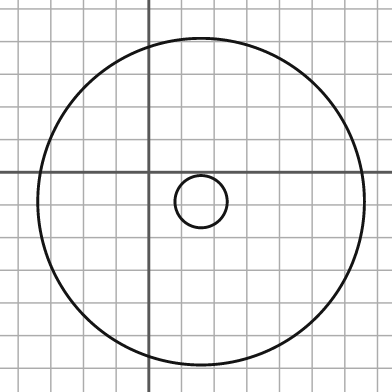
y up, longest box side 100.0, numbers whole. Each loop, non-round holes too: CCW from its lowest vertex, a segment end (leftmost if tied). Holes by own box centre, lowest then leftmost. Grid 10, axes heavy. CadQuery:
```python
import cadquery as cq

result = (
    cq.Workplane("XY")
    .moveTo(16.0, -9.0)
    .circle(50.0)
    .moveTo(16.0, -9.0)
    .circle(8.0)
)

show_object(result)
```